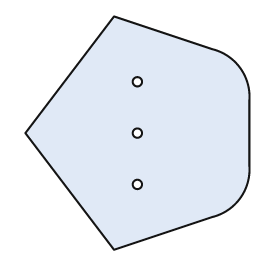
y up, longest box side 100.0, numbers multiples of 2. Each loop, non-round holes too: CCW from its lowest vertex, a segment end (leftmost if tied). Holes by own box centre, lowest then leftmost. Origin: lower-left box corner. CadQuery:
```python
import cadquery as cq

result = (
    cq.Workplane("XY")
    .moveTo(38.0, 0.0)
    .lineTo(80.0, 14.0)
    .threePointArc((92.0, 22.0), (96.0, 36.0))
    .lineTo(96.0, 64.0)
    .threePointArc((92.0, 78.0), (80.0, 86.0))
    .lineTo(38.0, 100.0)
    .lineTo(0.0, 50.0)
    .close()
    .moveTo(48.0, 28.0)
    .circle(2.0)
    .moveTo(48.0, 50.0)
    .circle(2.0)
    .moveTo(48.0, 72.0)
    .circle(2.0)
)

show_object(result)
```